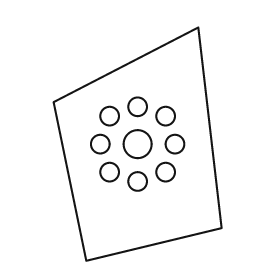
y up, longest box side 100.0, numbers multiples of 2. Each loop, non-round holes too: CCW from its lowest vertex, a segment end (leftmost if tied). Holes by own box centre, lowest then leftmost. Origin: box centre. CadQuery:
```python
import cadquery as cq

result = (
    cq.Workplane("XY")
    .moveTo(-22.0, -50.0)
    .lineTo(36.0, -36.0)
    .lineTo(26.0, 50.0)
    .lineTo(-36.0, 18.0)
    .close()
    .moveTo(0.0, -16.0)
    .circle(4.0)
    .moveTo(-12.0, -12.0)
    .circle(4.0)
    .moveTo(12.0, -12.0)
    .circle(4.0)
    .moveTo(-16.0, 0.0)
    .circle(4.0)
    .moveTo(0.0, 0.0)
    .circle(6.0)
    .moveTo(16.0, 0.0)
    .circle(4.0)
    .moveTo(-12.0, 12.0)
    .circle(4.0)
    .moveTo(12.0, 12.0)
    .circle(4.0)
    .moveTo(0.0, 16.0)
    .circle(4.0)
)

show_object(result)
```